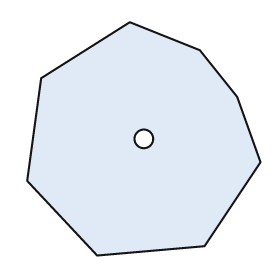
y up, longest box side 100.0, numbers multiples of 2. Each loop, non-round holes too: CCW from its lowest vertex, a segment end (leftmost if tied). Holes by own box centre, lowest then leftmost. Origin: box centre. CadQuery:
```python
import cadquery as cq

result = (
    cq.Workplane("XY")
    .moveTo(-20.0, -50.0)
    .lineTo(26.0, -46.0)
    .lineTo(50.0, -10.0)
    .lineTo(40.0, 18.0)
    .lineTo(24.0, 38.0)
    .lineTo(-6.0, 50.0)
    .lineTo(-44.0, 26.0)
    .lineTo(-50.0, -18.0)
    .close()
    .moveTo(0.0, 0.0)
    .circle(4.0)
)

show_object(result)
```